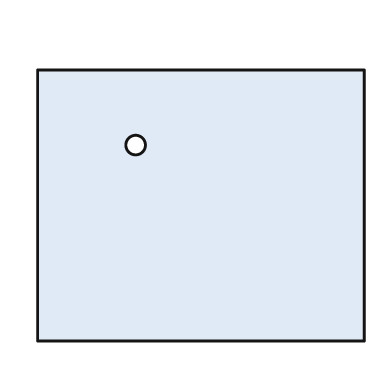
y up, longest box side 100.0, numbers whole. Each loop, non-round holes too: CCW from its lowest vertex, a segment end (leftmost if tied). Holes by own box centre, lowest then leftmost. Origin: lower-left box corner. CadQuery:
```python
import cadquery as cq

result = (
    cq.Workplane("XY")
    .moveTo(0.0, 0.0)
    .lineTo(100.0, 0.0)
    .lineTo(100.0, 83.0)
    .lineTo(0.0, 83.0)
    .close()
    .moveTo(30.0, 60.0)
    .circle(3.0)
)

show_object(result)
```